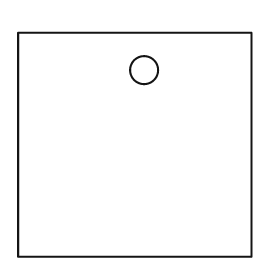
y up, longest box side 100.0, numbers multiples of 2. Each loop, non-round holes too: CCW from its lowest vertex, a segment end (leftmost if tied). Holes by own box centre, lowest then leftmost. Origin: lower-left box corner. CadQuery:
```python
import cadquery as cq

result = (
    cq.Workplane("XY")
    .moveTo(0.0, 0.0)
    .lineTo(100.0, 0.0)
    .lineTo(100.0, 96.0)
    .lineTo(0.0, 96.0)
    .close()
    .moveTo(54.0, 80.0)
    .circle(6.0)
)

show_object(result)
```